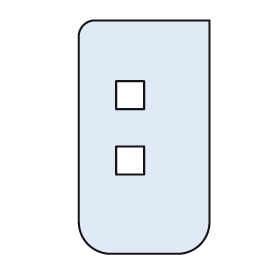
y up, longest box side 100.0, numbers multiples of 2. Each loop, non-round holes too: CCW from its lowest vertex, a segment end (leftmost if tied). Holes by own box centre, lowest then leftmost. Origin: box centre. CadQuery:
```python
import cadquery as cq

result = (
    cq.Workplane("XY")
    .moveTo(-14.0, -50.0)
    .lineTo(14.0, -50.0)
    .threePointArc((24.0, -46.0), (28.0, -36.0))
    .lineTo(28.0, 50.0)
    .lineTo(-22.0, 50.0)
    .threePointArc((-26.0, 48.0), (-28.0, 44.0))
    .lineTo(-28.0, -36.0)
    .threePointArc((-24.0, -46.0), (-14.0, -50.0))
    .close()
    .moveTo(-12.0, -16.0)
    .lineTo(0.0, -16.0)
    .lineTo(0.0, -4.0)
    .lineTo(-12.0, -4.0)
    .close()
    .moveTo(-12.0, 12.0)
    .lineTo(0.0, 12.0)
    .lineTo(0.0, 24.0)
    .lineTo(-12.0, 24.0)
    .close()
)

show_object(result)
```